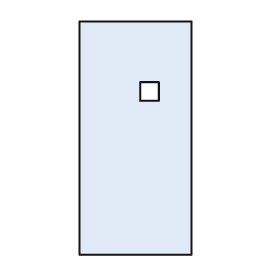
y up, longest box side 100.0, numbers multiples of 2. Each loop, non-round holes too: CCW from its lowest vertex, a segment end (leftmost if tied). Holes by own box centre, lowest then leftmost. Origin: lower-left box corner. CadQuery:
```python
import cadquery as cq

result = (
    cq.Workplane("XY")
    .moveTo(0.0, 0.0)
    .lineTo(48.0, 0.0)
    .lineTo(48.0, 100.0)
    .lineTo(0.0, 100.0)
    .close()
    .moveTo(26.0, 66.0)
    .lineTo(34.0, 66.0)
    .lineTo(34.0, 74.0)
    .lineTo(26.0, 74.0)
    .close()
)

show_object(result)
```